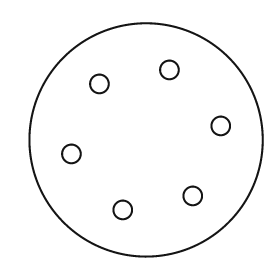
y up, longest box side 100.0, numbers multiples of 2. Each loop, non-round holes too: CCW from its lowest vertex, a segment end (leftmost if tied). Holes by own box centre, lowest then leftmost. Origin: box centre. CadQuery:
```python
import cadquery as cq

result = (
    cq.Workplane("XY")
    .moveTo(0.0, 0.0)
    .circle(50.0)
    .moveTo(-10.0, -30.0)
    .circle(4.0)
    .moveTo(20.0, -24.0)
    .circle(4.0)
    .moveTo(-32.0, -6.0)
    .circle(4.0)
    .moveTo(32.0, 6.0)
    .circle(4.0)
    .moveTo(-20.0, 24.0)
    .circle(4.0)
    .moveTo(10.0, 30.0)
    .circle(4.0)
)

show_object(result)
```